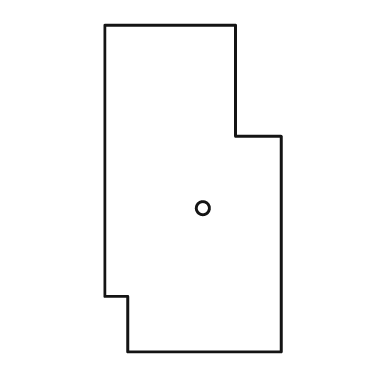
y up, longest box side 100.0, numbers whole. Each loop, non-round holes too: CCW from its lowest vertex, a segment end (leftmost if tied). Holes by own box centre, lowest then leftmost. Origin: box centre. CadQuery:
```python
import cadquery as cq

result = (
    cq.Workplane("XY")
    .moveTo(-20.0, -50.0)
    .lineTo(27.0, -50.0)
    .lineTo(27.0, 16.0)
    .lineTo(13.0, 16.0)
    .lineTo(13.0, 50.0)
    .lineTo(-27.0, 50.0)
    .lineTo(-27.0, -33.0)
    .lineTo(-20.0, -33.0)
    .close()
    .moveTo(3.0, -6.0)
    .circle(2.0)
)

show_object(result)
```